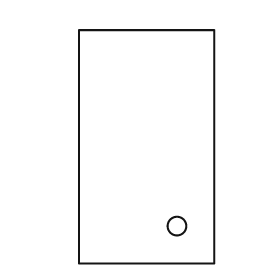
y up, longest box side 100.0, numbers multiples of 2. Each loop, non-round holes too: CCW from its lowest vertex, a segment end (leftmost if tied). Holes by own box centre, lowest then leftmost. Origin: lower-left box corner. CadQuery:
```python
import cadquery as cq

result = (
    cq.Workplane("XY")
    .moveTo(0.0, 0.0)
    .lineTo(58.0, 0.0)
    .lineTo(58.0, 100.0)
    .lineTo(0.0, 100.0)
    .close()
    .moveTo(42.0, 16.0)
    .circle(4.0)
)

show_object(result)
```